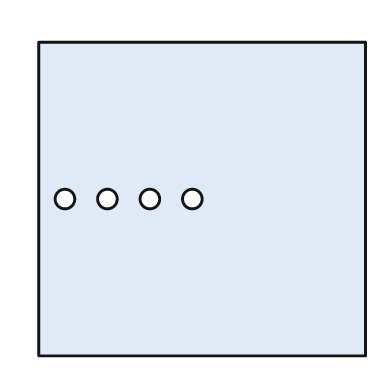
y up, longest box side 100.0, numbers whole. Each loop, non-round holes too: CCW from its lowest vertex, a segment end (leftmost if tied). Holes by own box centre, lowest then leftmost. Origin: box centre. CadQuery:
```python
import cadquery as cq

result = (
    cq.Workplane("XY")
    .moveTo(-50.0, -48.0)
    .lineTo(50.0, -48.0)
    .lineTo(50.0, 48.0)
    .lineTo(-50.0, 48.0)
    .close()
    .moveTo(-42.0, 0.0)
    .circle(3.0)
    .moveTo(-29.0, 0.0)
    .circle(3.0)
    .moveTo(-16.0, 0.0)
    .circle(3.0)
    .moveTo(-3.0, 0.0)
    .circle(3.0)
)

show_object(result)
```